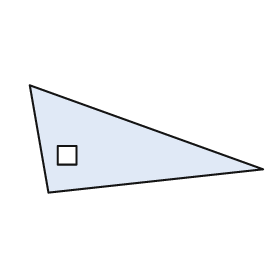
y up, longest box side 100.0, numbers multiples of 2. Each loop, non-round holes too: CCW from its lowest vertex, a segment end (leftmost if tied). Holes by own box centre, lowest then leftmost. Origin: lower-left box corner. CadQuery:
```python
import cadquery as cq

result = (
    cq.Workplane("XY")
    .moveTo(8.0, 0.0)
    .lineTo(100.0, 10.0)
    .lineTo(0.0, 46.0)
    .close()
    .moveTo(12.0, 12.0)
    .lineTo(20.0, 12.0)
    .lineTo(20.0, 20.0)
    .lineTo(12.0, 20.0)
    .close()
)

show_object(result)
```